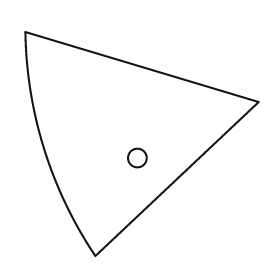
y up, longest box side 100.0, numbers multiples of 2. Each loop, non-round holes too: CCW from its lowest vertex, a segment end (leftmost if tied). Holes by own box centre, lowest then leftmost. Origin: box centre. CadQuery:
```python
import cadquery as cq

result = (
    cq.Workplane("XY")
    .moveTo(-20.0, -48.0)
    .lineTo(50.0, 18.0)
    .lineTo(-50.0, 48.0)
    .threePointArc((-42.0, -2.0), (-20.0, -48.0))
    .close()
    .moveTo(-2.0, -6.0)
    .circle(4.0)
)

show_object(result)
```